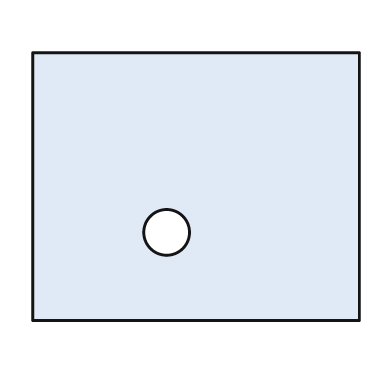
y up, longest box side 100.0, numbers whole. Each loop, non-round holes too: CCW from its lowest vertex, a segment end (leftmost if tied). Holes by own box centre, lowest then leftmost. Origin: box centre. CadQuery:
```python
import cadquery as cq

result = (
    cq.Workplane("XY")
    .moveTo(-50.0, -41.0)
    .lineTo(50.0, -41.0)
    .lineTo(50.0, 41.0)
    .lineTo(-50.0, 41.0)
    .close()
    .moveTo(-9.0, -14.0)
    .circle(7.0)
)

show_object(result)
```